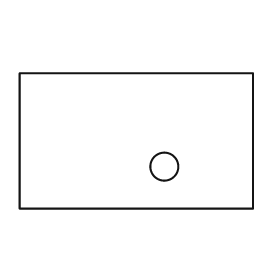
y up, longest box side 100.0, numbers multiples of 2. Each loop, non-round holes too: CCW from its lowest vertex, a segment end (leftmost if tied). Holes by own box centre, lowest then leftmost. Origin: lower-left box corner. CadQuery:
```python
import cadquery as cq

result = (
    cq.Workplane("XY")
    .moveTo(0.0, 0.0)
    .lineTo(100.0, 0.0)
    .lineTo(100.0, 58.0)
    .lineTo(0.0, 58.0)
    .close()
    .moveTo(62.0, 18.0)
    .circle(6.0)
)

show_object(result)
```